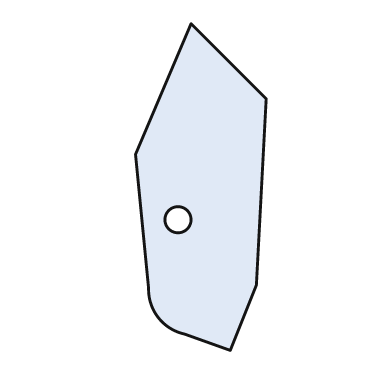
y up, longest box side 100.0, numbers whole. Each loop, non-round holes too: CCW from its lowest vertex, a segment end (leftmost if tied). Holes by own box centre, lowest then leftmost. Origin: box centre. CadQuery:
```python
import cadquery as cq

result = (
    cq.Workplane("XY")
    .moveTo(9.0, -50.0)
    .lineTo(17.0, -30.0)
    .lineTo(20.0, 27.0)
    .lineTo(-3.0, 50.0)
    .lineTo(-20.0, 10.0)
    .lineTo(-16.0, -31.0)
    .threePointArc((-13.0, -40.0), (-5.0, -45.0))
    .close()
    .moveTo(-7.0, -10.0)
    .circle(4.0)
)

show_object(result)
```